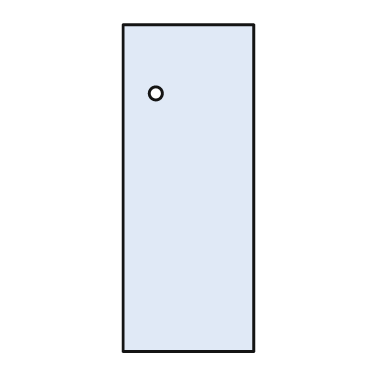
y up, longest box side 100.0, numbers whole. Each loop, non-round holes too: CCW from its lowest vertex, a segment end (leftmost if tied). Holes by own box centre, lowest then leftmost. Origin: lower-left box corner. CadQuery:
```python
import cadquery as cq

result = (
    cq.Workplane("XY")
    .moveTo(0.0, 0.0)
    .lineTo(40.0, 0.0)
    .lineTo(40.0, 100.0)
    .lineTo(0.0, 100.0)
    .close()
    .moveTo(10.0, 79.0)
    .circle(2.0)
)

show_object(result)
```